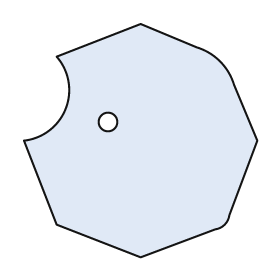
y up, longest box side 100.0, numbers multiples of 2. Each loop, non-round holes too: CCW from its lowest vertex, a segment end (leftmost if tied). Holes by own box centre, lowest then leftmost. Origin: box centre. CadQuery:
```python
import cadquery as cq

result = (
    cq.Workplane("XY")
    .moveTo(0.0, -50.0)
    .lineTo(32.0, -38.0)
    .threePointArc((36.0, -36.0), (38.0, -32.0))
    .lineTo(50.0, 0.0)
    .lineTo(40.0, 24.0)
    .threePointArc((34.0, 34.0), (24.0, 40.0))
    .lineTo(0.0, 50.0)
    .lineTo(-36.0, 36.0)
    .threePointArc((-32.0, 14.0), (-50.0, 0.0))
    .lineTo(-36.0, -36.0)
    .close()
    .moveTo(-14.0, 8.0)
    .circle(4.0)
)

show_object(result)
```